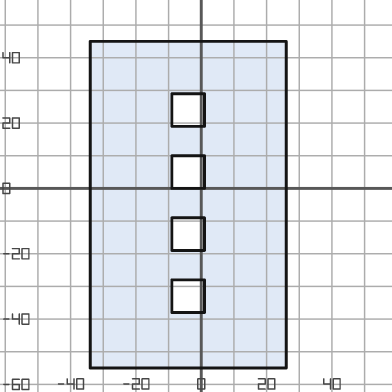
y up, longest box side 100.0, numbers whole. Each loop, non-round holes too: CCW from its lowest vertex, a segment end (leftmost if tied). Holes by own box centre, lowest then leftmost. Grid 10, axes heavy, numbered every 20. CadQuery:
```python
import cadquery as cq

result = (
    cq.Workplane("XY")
    .moveTo(-34.0, -55.0)
    .lineTo(26.0, -55.0)
    .lineTo(26.0, 45.0)
    .lineTo(-34.0, 45.0)
    .close()
    .moveTo(-9.0, -38.0)
    .lineTo(1.0, -38.0)
    .lineTo(1.0, -28.0)
    .lineTo(-9.0, -28.0)
    .close()
    .moveTo(-9.0, -19.0)
    .lineTo(1.0, -19.0)
    .lineTo(1.0, -9.0)
    .lineTo(-9.0, -9.0)
    .close()
    .moveTo(-9.0, 0.0)
    .lineTo(1.0, 0.0)
    .lineTo(1.0, 10.0)
    .lineTo(-9.0, 10.0)
    .close()
    .moveTo(-9.0, 19.0)
    .lineTo(1.0, 19.0)
    .lineTo(1.0, 29.0)
    .lineTo(-9.0, 29.0)
    .close()
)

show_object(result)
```